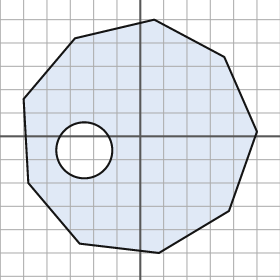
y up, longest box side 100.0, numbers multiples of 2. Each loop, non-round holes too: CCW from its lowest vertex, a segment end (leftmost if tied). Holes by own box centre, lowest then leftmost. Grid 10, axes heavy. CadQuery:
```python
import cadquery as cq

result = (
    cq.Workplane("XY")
    .moveTo(8.0, -50.0)
    .lineTo(38.0, -32.0)
    .lineTo(50.0, 2.0)
    .lineTo(36.0, 34.0)
    .lineTo(6.0, 50.0)
    .lineTo(-28.0, 42.0)
    .lineTo(-50.0, 16.0)
    .lineTo(-48.0, -20.0)
    .lineTo(-26.0, -46.0)
    .close()
    .moveTo(-24.0, -6.0)
    .circle(12.0)
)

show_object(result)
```